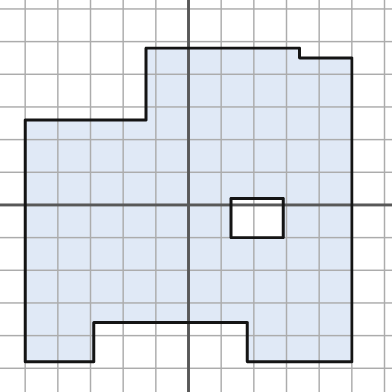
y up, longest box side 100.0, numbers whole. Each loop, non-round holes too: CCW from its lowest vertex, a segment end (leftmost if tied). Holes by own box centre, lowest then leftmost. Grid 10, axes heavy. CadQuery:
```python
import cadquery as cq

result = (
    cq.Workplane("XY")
    .moveTo(-50.0, -48.0)
    .lineTo(-29.0, -48.0)
    .lineTo(-29.0, -36.0)
    .lineTo(18.0, -36.0)
    .lineTo(18.0, -48.0)
    .lineTo(50.0, -48.0)
    .lineTo(50.0, 45.0)
    .lineTo(34.0, 45.0)
    .lineTo(34.0, 48.0)
    .lineTo(-13.0, 48.0)
    .lineTo(-13.0, 26.0)
    .lineTo(-50.0, 26.0)
    .close()
    .moveTo(13.0, -10.0)
    .lineTo(29.0, -10.0)
    .lineTo(29.0, 2.0)
    .lineTo(13.0, 2.0)
    .close()
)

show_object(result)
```